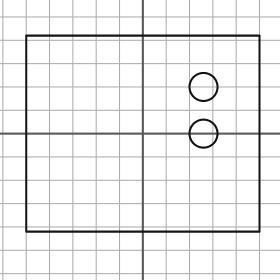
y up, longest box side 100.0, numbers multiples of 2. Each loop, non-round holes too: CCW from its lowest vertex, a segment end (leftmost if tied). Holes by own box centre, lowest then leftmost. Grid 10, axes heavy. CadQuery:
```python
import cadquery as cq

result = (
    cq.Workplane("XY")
    .moveTo(-50.0, -42.0)
    .lineTo(50.0, -42.0)
    .lineTo(50.0, 42.0)
    .lineTo(-50.0, 42.0)
    .close()
    .moveTo(26.0, 0.0)
    .circle(6.0)
    .moveTo(26.0, 20.0)
    .circle(6.0)
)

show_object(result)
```